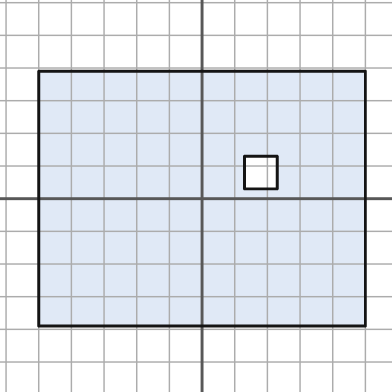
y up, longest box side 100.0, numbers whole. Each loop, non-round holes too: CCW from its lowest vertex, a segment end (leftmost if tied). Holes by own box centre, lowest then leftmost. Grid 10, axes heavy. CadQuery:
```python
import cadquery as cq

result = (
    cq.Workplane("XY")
    .moveTo(-50.0, -39.0)
    .lineTo(50.0, -39.0)
    .lineTo(50.0, 39.0)
    .lineTo(-50.0, 39.0)
    .close()
    .moveTo(13.0, 3.0)
    .lineTo(23.0, 3.0)
    .lineTo(23.0, 13.0)
    .lineTo(13.0, 13.0)
    .close()
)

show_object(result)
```